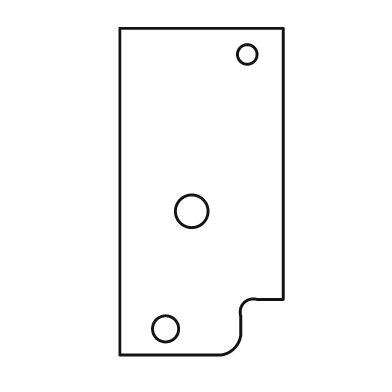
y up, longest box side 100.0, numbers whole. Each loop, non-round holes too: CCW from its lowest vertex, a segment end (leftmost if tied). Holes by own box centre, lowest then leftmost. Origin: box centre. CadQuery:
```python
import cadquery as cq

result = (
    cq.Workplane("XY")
    .moveTo(-25.0, -50.0)
    .lineTo(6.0, -50.0)
    .threePointArc((10.0, -48.0), (12.0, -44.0))
    .lineTo(12.0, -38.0)
    .threePointArc((13.0, -34.0), (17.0, -33.0))
    .lineTo(25.0, -33.0)
    .lineTo(25.0, 50.0)
    .lineTo(-25.0, 50.0)
    .close()
    .moveTo(-11.0, -42.0)
    .circle(4.0)
    .moveTo(-3.0, -6.0)
    .circle(5.0)
    .moveTo(14.0, 42.0)
    .circle(3.0)
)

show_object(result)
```